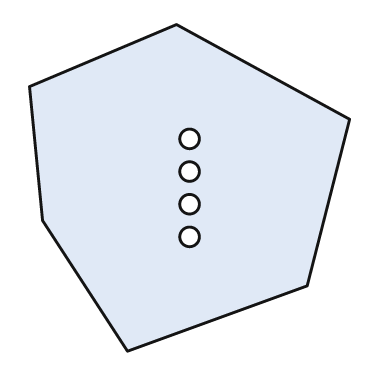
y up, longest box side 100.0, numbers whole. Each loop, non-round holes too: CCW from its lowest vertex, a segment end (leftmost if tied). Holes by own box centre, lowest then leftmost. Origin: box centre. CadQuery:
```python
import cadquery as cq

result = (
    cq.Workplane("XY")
    .moveTo(-19.0, -50.0)
    .lineTo(36.0, -30.0)
    .lineTo(49.0, 21.0)
    .lineTo(-4.0, 50.0)
    .lineTo(-49.0, 31.0)
    .lineTo(-45.0, -10.0)
    .close()
    .moveTo(0.0, -15.0)
    .circle(3.0)
    .moveTo(0.0, -5.0)
    .circle(3.0)
    .moveTo(0.0, 5.0)
    .circle(3.0)
    .moveTo(0.0, 15.0)
    .circle(3.0)
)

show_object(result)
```